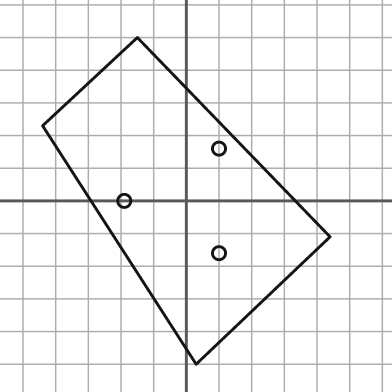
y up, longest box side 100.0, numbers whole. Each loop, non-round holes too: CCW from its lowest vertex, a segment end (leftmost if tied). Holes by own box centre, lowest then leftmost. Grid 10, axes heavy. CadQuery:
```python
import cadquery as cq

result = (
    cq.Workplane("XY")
    .moveTo(3.0, -50.0)
    .lineTo(44.0, -11.0)
    .lineTo(-15.0, 50.0)
    .lineTo(-44.0, 23.0)
    .close()
    .moveTo(10.0, -16.0)
    .circle(2.0)
    .moveTo(-19.0, 0.0)
    .circle(2.0)
    .moveTo(10.0, 16.0)
    .circle(2.0)
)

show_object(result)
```